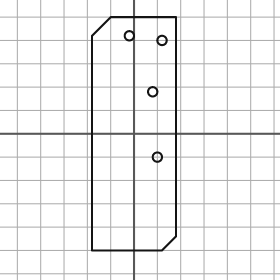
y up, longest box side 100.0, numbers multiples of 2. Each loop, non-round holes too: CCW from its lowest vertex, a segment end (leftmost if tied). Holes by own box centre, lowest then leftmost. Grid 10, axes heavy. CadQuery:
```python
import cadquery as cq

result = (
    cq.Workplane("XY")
    .moveTo(-18.0, -50.0)
    .lineTo(12.0, -50.0)
    .lineTo(18.0, -44.0)
    .lineTo(18.0, 50.0)
    .lineTo(-10.0, 50.0)
    .lineTo(-18.0, 42.0)
    .close()
    .moveTo(10.0, -10.0)
    .circle(2.0)
    .moveTo(8.0, 18.0)
    .circle(2.0)
    .moveTo(12.0, 40.0)
    .circle(2.0)
    .moveTo(-2.0, 42.0)
    .circle(2.0)
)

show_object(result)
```